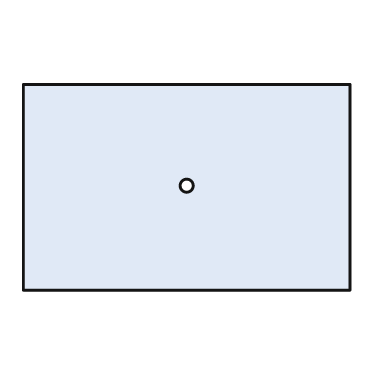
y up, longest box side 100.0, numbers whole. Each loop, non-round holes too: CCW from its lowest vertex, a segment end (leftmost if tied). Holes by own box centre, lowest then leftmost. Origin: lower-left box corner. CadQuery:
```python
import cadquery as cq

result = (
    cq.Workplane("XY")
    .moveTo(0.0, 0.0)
    .lineTo(100.0, 0.0)
    .lineTo(100.0, 63.0)
    .lineTo(0.0, 63.0)
    .close()
    .moveTo(50.0, 32.0)
    .circle(2.0)
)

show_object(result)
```